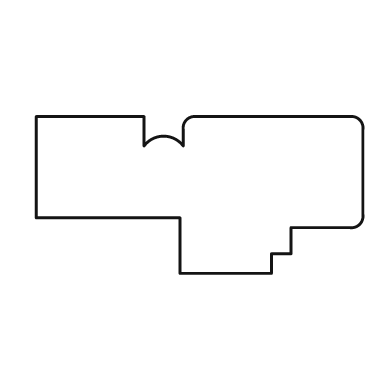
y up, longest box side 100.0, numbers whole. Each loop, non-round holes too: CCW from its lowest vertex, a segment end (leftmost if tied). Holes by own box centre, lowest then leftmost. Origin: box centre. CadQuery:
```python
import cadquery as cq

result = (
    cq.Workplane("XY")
    .moveTo(-6.0, -24.0)
    .lineTo(22.0, -24.0)
    .lineTo(22.0, -18.0)
    .lineTo(28.0, -18.0)
    .lineTo(28.0, -10.0)
    .lineTo(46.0, -10.0)
    .threePointArc((49.0, -9.0), (50.0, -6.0))
    .lineTo(50.0, 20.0)
    .threePointArc((49.0, 23.0), (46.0, 24.0))
    .lineTo(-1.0, 24.0)
    .threePointArc((-4.0, 23.0), (-5.0, 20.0))
    .lineTo(-5.0, 15.0)
    .threePointArc((-11.0, 18.0), (-17.0, 15.0))
    .lineTo(-17.0, 24.0)
    .lineTo(-50.0, 24.0)
    .lineTo(-50.0, -7.0)
    .lineTo(-6.0, -7.0)
    .close()
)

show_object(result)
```